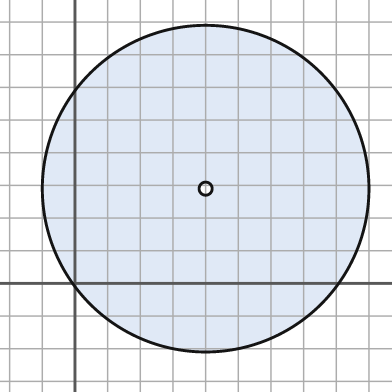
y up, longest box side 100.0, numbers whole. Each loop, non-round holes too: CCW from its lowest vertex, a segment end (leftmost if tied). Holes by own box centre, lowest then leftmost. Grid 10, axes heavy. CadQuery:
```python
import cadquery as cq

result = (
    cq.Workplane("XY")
    .moveTo(40.0, 29.0)
    .circle(50.0)
    .moveTo(40.0, 29.0)
    .circle(2.0)
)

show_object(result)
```